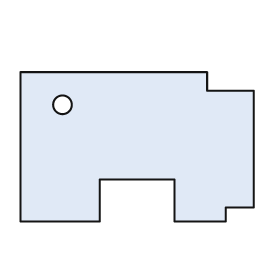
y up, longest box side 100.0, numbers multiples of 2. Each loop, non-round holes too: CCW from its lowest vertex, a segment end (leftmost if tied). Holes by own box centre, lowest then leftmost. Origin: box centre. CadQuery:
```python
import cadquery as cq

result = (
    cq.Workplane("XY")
    .moveTo(-50.0, -32.0)
    .lineTo(-16.0, -32.0)
    .lineTo(-16.0, -14.0)
    .lineTo(16.0, -14.0)
    .lineTo(16.0, -32.0)
    .lineTo(38.0, -32.0)
    .lineTo(38.0, -26.0)
    .lineTo(50.0, -26.0)
    .lineTo(50.0, 24.0)
    .lineTo(30.0, 24.0)
    .lineTo(30.0, 32.0)
    .lineTo(-50.0, 32.0)
    .close()
    .moveTo(-32.0, 18.0)
    .circle(4.0)
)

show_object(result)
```